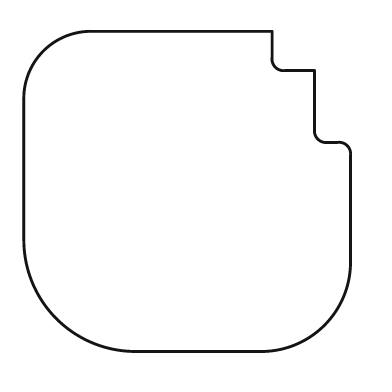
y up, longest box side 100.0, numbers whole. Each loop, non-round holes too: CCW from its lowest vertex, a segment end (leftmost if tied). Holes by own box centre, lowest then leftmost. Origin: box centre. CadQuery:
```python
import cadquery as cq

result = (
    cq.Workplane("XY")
    .moveTo(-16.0, -49.0)
    .lineTo(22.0, -49.0)
    .threePointArc((42.0, -41.0), (50.0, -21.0))
    .lineTo(50.0, 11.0)
    .threePointArc((49.0, 14.0), (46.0, 15.0))
    .lineTo(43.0, 15.0)
    .threePointArc((40.0, 16.0), (39.0, 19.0))
    .lineTo(39.0, 37.0)
    .lineTo(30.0, 37.0)
    .threePointArc((27.0, 38.0), (26.0, 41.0))
    .lineTo(26.0, 49.0)
    .lineTo(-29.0, 49.0)
    .threePointArc((-44.0, 43.0), (-50.0, 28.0))
    .lineTo(-50.0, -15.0)
    .threePointArc((-40.0, -39.0), (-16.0, -49.0))
    .close()
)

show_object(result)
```